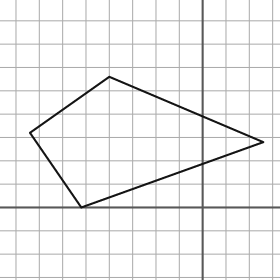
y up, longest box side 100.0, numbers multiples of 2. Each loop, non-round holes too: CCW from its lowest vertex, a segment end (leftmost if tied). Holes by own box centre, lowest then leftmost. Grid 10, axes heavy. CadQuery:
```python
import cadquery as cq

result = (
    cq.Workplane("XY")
    .moveTo(-52.0, 0.0)
    .lineTo(26.0, 28.0)
    .lineTo(-40.0, 56.0)
    .lineTo(-74.0, 32.0)
    .close()
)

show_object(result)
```